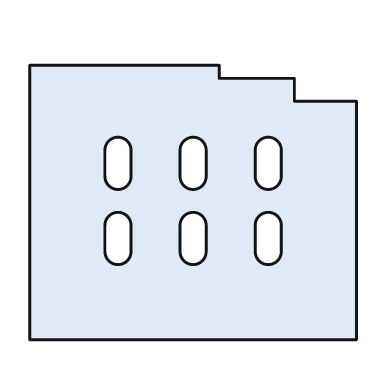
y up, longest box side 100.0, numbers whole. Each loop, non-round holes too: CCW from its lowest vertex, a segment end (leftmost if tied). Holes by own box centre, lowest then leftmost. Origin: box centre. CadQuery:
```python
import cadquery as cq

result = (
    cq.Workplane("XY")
    .moveTo(-50.0, -42.0)
    .lineTo(50.0, -42.0)
    .lineTo(50.0, 31.0)
    .lineTo(31.0, 31.0)
    .lineTo(31.0, 38.0)
    .lineTo(8.0, 38.0)
    .lineTo(8.0, 42.0)
    .lineTo(-50.0, 42.0)
    .close()
    .moveTo(-27.0, -15.0)
    .threePointArc((-23.0, -19.0), (-19.0, -15.0))
    .lineTo(-19.0, -7.0)
    .threePointArc((-23.0, -3.0), (-27.0, -7.0))
    .close()
    .moveTo(-4.0, -15.0)
    .threePointArc((0.0, -19.0), (4.0, -15.0))
    .lineTo(4.0, -7.0)
    .threePointArc((0.0, -3.0), (-4.0, -7.0))
    .close()
    .moveTo(19.0, -15.0)
    .threePointArc((23.0, -19.0), (27.0, -15.0))
    .lineTo(27.0, -7.0)
    .threePointArc((23.0, -3.0), (19.0, -7.0))
    .close()
    .moveTo(-27.0, 8.0)
    .threePointArc((-23.0, 4.0), (-19.0, 8.0))
    .lineTo(-19.0, 16.0)
    .threePointArc((-23.0, 20.0), (-27.0, 16.0))
    .close()
    .moveTo(-4.0, 8.0)
    .threePointArc((0.0, 4.0), (4.0, 8.0))
    .lineTo(4.0, 16.0)
    .threePointArc((0.0, 20.0), (-4.0, 16.0))
    .close()
    .moveTo(19.0, 8.0)
    .threePointArc((23.0, 4.0), (27.0, 8.0))
    .lineTo(27.0, 16.0)
    .threePointArc((23.0, 20.0), (19.0, 16.0))
    .close()
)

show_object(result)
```